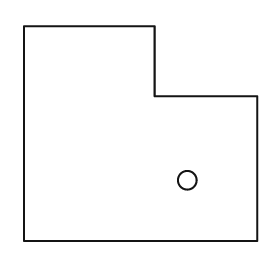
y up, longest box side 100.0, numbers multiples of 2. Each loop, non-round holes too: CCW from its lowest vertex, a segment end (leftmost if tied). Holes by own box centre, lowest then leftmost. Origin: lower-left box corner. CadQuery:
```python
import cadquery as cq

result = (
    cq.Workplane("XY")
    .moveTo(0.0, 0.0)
    .lineTo(100.0, 0.0)
    .lineTo(100.0, 62.0)
    .lineTo(56.0, 62.0)
    .lineTo(56.0, 92.0)
    .lineTo(0.0, 92.0)
    .close()
    .moveTo(70.0, 26.0)
    .circle(4.0)
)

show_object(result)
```